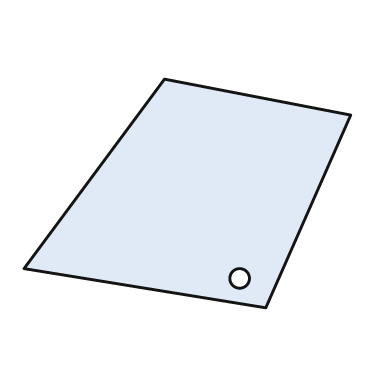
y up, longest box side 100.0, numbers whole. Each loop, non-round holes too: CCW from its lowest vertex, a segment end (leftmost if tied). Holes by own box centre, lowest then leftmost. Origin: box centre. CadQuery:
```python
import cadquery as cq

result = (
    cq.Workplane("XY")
    .moveTo(24.0, -35.0)
    .lineTo(50.0, 24.0)
    .lineTo(-7.0, 35.0)
    .lineTo(-50.0, -23.0)
    .close()
    .moveTo(16.0, -26.0)
    .circle(3.0)
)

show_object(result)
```